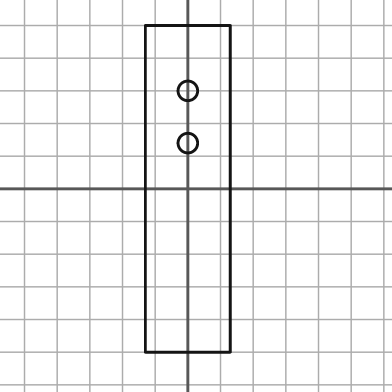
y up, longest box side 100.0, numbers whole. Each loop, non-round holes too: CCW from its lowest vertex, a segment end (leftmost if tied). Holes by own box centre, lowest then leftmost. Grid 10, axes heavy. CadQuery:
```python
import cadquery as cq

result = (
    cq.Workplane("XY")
    .moveTo(-13.0, -50.0)
    .lineTo(13.0, -50.0)
    .lineTo(13.0, 50.0)
    .lineTo(-13.0, 50.0)
    .close()
    .moveTo(0.0, 14.0)
    .circle(3.0)
    .moveTo(0.0, 30.0)
    .circle(3.0)
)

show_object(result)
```